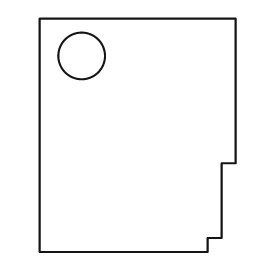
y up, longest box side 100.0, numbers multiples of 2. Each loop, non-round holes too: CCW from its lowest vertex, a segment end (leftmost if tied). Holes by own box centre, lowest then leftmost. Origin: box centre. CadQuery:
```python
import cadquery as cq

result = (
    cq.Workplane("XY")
    .moveTo(-42.0, -50.0)
    .lineTo(30.0, -50.0)
    .lineTo(30.0, -44.0)
    .lineTo(36.0, -44.0)
    .lineTo(36.0, -12.0)
    .lineTo(42.0, -12.0)
    .lineTo(42.0, 50.0)
    .lineTo(-42.0, 50.0)
    .close()
    .moveTo(-24.0, 34.0)
    .circle(10.0)
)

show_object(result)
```